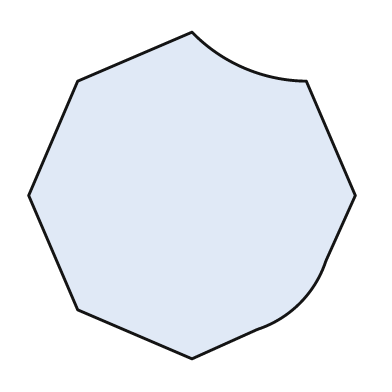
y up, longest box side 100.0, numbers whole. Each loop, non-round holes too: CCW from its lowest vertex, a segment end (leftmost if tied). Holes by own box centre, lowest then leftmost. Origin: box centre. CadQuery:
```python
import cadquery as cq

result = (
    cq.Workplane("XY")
    .moveTo(0.0, -50.0)
    .lineTo(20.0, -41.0)
    .threePointArc((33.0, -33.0), (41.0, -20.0))
    .lineTo(50.0, 0.0)
    .lineTo(35.0, 35.0)
    .threePointArc((16.0, 39.0), (0.0, 50.0))
    .lineTo(-35.0, 35.0)
    .lineTo(-50.0, 0.0)
    .lineTo(-35.0, -35.0)
    .close()
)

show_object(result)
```